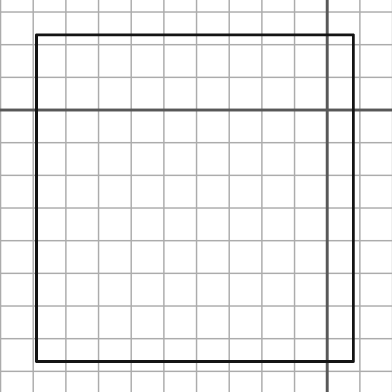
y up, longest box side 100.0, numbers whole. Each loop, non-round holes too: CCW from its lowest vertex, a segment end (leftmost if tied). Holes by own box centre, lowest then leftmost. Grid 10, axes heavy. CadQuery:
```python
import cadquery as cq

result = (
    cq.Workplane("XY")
    .moveTo(-89.0, -77.0)
    .lineTo(8.0, -77.0)
    .lineTo(8.0, 23.0)
    .lineTo(-89.0, 23.0)
    .close()
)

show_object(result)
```